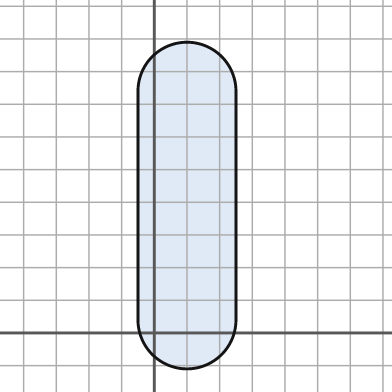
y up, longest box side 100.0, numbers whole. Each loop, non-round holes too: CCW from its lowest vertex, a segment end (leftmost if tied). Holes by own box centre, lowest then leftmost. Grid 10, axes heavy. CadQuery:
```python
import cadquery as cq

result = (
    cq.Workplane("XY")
    .moveTo(-5.0, 4.0)
    .threePointArc((10.0, -11.0), (25.0, 4.0))
    .lineTo(25.0, 74.0)
    .threePointArc((10.0, 89.0), (-5.0, 74.0))
    .close()
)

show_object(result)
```